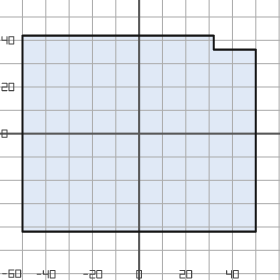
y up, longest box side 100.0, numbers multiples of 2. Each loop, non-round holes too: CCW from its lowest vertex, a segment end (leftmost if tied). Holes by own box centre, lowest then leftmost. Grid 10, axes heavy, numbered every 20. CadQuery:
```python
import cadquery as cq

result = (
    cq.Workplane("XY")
    .moveTo(-50.0, -42.0)
    .lineTo(50.0, -42.0)
    .lineTo(50.0, 36.0)
    .lineTo(32.0, 36.0)
    .lineTo(32.0, 42.0)
    .lineTo(-50.0, 42.0)
    .close()
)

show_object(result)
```